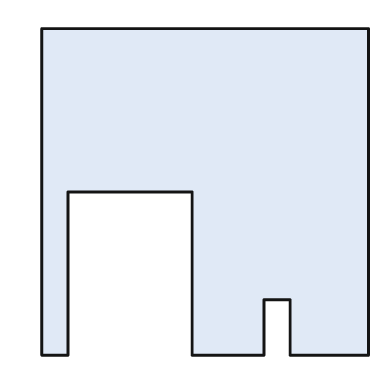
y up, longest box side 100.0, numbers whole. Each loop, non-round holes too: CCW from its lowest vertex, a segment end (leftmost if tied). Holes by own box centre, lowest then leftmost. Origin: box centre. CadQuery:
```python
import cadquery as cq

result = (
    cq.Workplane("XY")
    .moveTo(-50.0, -50.0)
    .lineTo(-42.0, -50.0)
    .lineTo(-42.0, 0.0)
    .lineTo(-4.0, 0.0)
    .lineTo(-4.0, -50.0)
    .lineTo(18.0, -50.0)
    .lineTo(18.0, -33.0)
    .lineTo(26.0, -33.0)
    .lineTo(26.0, -50.0)
    .lineTo(50.0, -50.0)
    .lineTo(50.0, 50.0)
    .lineTo(-50.0, 50.0)
    .close()
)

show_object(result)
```